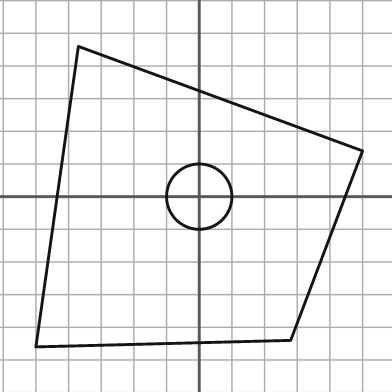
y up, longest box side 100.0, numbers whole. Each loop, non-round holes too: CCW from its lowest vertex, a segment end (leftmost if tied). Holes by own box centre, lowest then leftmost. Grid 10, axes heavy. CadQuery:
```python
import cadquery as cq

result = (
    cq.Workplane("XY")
    .moveTo(-50.0, -46.0)
    .lineTo(28.0, -44.0)
    .lineTo(50.0, 14.0)
    .lineTo(-37.0, 46.0)
    .close()
    .moveTo(0.0, 0.0)
    .circle(10.0)
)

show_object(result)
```